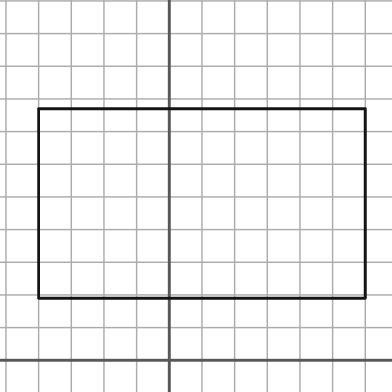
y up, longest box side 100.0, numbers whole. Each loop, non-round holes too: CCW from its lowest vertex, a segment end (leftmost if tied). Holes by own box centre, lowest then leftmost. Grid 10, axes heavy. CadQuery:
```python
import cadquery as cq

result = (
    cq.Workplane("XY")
    .moveTo(-40.0, 19.0)
    .lineTo(60.0, 19.0)
    .lineTo(60.0, 77.0)
    .lineTo(-40.0, 77.0)
    .close()
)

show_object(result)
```